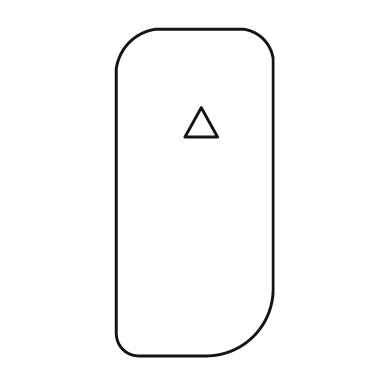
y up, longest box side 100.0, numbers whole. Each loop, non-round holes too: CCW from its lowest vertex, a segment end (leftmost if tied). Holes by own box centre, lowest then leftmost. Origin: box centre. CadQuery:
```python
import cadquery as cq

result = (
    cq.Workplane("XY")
    .moveTo(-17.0, -50.0)
    .lineTo(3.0, -50.0)
    .threePointArc((18.0, -44.0), (24.0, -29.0))
    .lineTo(24.0, 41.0)
    .threePointArc((21.0, 47.0), (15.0, 50.0))
    .lineTo(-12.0, 50.0)
    .threePointArc((-20.0, 46.0), (-24.0, 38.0))
    .lineTo(-24.0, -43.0)
    .threePointArc((-22.0, -48.0), (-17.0, -50.0))
    .close()
    .moveTo(-3.0, 17.0)
    .lineTo(7.0, 17.0)
    .lineTo(2.0, 26.0)
    .close()
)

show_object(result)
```